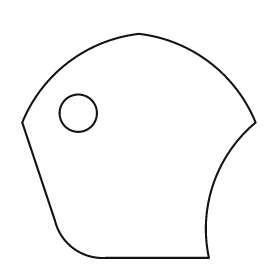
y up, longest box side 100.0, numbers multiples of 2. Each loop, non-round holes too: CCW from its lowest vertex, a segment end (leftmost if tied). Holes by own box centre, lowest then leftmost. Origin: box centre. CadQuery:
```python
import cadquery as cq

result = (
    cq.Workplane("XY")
    .moveTo(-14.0, -48.0)
    .lineTo(30.0, -48.0)
    .threePointArc((32.0, -16.0), (50.0, 10.0))
    .threePointArc((30.0, 36.0), (0.0, 48.0))
    .threePointArc((-30.0, 36.0), (-50.0, 10.0))
    .lineTo(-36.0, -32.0)
    .threePointArc((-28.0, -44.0), (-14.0, -48.0))
    .close()
    .moveTo(-26.0, 14.0)
    .circle(8.0)
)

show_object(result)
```